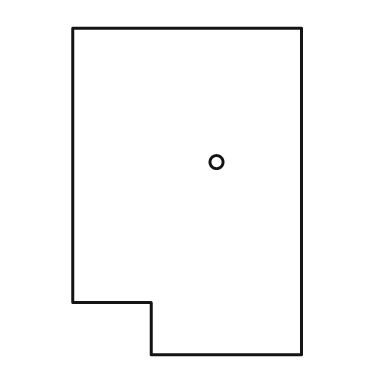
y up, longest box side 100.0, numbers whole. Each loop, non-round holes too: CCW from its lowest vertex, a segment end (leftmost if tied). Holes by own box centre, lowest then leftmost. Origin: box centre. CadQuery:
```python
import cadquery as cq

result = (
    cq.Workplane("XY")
    .moveTo(-11.0, -50.0)
    .lineTo(35.0, -50.0)
    .lineTo(35.0, 50.0)
    .lineTo(-35.0, 50.0)
    .lineTo(-35.0, -34.0)
    .lineTo(-11.0, -34.0)
    .close()
    .moveTo(9.0, 9.0)
    .circle(2.0)
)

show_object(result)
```